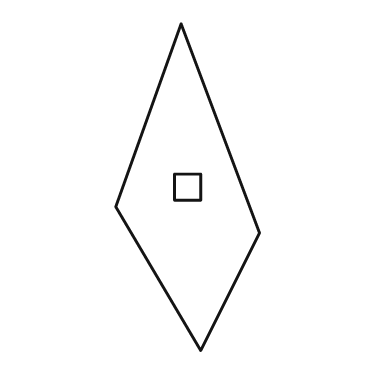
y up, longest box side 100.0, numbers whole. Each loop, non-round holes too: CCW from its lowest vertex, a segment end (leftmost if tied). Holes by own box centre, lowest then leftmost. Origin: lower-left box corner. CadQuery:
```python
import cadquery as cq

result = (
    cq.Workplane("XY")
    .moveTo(26.0, 0.0)
    .lineTo(44.0, 36.0)
    .lineTo(20.0, 100.0)
    .lineTo(0.0, 44.0)
    .close()
    .moveTo(18.0, 46.0)
    .lineTo(26.0, 46.0)
    .lineTo(26.0, 54.0)
    .lineTo(18.0, 54.0)
    .close()
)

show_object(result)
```